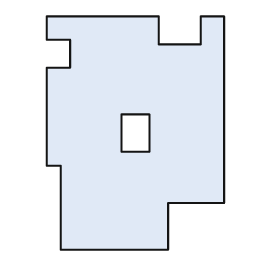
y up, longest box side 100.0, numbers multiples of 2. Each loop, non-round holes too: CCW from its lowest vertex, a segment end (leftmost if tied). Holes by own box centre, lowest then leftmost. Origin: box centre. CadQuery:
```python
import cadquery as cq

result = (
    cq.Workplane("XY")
    .moveTo(-32.0, -50.0)
    .lineTo(14.0, -50.0)
    .lineTo(14.0, -30.0)
    .lineTo(38.0, -30.0)
    .lineTo(38.0, 50.0)
    .lineTo(28.0, 50.0)
    .lineTo(28.0, 38.0)
    .lineTo(10.0, 38.0)
    .lineTo(10.0, 50.0)
    .lineTo(-38.0, 50.0)
    .lineTo(-38.0, 40.0)
    .lineTo(-28.0, 40.0)
    .lineTo(-28.0, 28.0)
    .lineTo(-38.0, 28.0)
    .lineTo(-38.0, -14.0)
    .lineTo(-32.0, -14.0)
    .close()
    .moveTo(-6.0, -8.0)
    .lineTo(6.0, -8.0)
    .lineTo(6.0, 8.0)
    .lineTo(-6.0, 8.0)
    .close()
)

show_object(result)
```